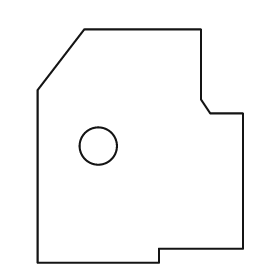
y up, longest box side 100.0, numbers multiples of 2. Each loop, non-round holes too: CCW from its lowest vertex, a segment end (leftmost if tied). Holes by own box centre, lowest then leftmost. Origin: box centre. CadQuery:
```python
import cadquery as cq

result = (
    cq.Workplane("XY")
    .moveTo(-44.0, -50.0)
    .lineTo(8.0, -50.0)
    .lineTo(8.0, -44.0)
    .lineTo(44.0, -44.0)
    .lineTo(44.0, 14.0)
    .lineTo(30.0, 14.0)
    .lineTo(26.0, 20.0)
    .lineTo(26.0, 50.0)
    .lineTo(-24.0, 50.0)
    .lineTo(-44.0, 24.0)
    .close()
    .moveTo(-18.0, 0.0)
    .circle(8.0)
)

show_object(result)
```